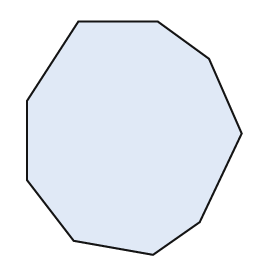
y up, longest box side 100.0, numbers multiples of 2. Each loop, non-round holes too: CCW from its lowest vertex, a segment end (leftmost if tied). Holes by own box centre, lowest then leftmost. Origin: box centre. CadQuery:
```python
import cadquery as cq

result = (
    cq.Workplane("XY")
    .moveTo(8.0, -50.0)
    .lineTo(28.0, -36.0)
    .lineTo(46.0, 2.0)
    .lineTo(32.0, 34.0)
    .lineTo(10.0, 50.0)
    .lineTo(-24.0, 50.0)
    .lineTo(-46.0, 16.0)
    .lineTo(-46.0, -18.0)
    .lineTo(-26.0, -44.0)
    .close()
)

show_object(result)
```